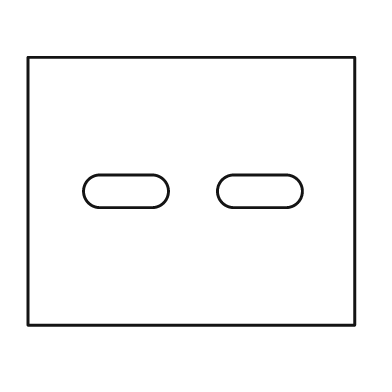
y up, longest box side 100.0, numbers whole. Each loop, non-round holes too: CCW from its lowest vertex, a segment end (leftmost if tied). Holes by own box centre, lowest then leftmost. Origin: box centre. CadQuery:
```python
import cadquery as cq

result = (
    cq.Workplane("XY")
    .moveTo(-50.0, -41.0)
    .lineTo(50.0, -41.0)
    .lineTo(50.0, 41.0)
    .lineTo(-50.0, 41.0)
    .close()
    .moveTo(-28.0, -5.0)
    .lineTo(-12.0, -5.0)
    .threePointArc((-7.0, 0.0), (-12.0, 5.0))
    .lineTo(-28.0, 5.0)
    .threePointArc((-33.0, 0.0), (-28.0, -5.0))
    .close()
    .moveTo(13.0, -5.0)
    .lineTo(29.0, -5.0)
    .threePointArc((34.0, 0.0), (29.0, 5.0))
    .lineTo(13.0, 5.0)
    .threePointArc((8.0, 0.0), (13.0, -5.0))
    .close()
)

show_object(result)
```